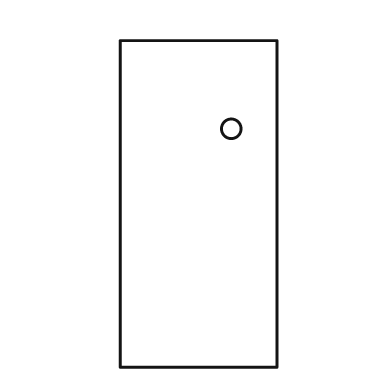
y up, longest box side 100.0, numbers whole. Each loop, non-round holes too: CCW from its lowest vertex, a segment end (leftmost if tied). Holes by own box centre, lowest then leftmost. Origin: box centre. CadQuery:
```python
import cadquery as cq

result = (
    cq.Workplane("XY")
    .moveTo(-24.0, -50.0)
    .lineTo(24.0, -50.0)
    .lineTo(24.0, 50.0)
    .lineTo(-24.0, 50.0)
    .close()
    .moveTo(10.0, 23.0)
    .circle(3.0)
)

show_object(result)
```